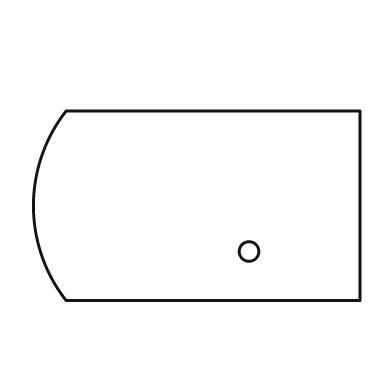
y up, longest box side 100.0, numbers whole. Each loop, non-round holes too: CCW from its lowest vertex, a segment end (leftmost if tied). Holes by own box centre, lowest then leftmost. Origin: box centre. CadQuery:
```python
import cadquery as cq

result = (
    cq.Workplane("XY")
    .moveTo(-40.0, -29.0)
    .lineTo(50.0, -29.0)
    .lineTo(50.0, 29.0)
    .lineTo(-40.0, 29.0)
    .threePointArc((-50.0, 0.0), (-40.0, -29.0))
    .close()
    .moveTo(16.0, -14.0)
    .circle(3.0)
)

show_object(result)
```